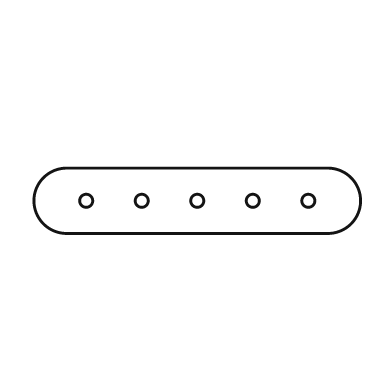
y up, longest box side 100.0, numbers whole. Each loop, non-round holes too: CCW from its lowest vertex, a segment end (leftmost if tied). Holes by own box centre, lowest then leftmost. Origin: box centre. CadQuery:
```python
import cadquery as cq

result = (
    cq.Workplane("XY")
    .moveTo(-40.0, -10.0)
    .lineTo(40.0, -10.0)
    .threePointArc((50.0, 0.0), (40.0, 10.0))
    .lineTo(-40.0, 10.0)
    .threePointArc((-50.0, 0.0), (-40.0, -10.0))
    .close()
    .moveTo(-34.0, 0.0)
    .circle(2.0)
    .moveTo(-17.0, 0.0)
    .circle(2.0)
    .moveTo(0.0, 0.0)
    .circle(2.0)
    .moveTo(17.0, 0.0)
    .circle(2.0)
    .moveTo(34.0, 0.0)
    .circle(2.0)
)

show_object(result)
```